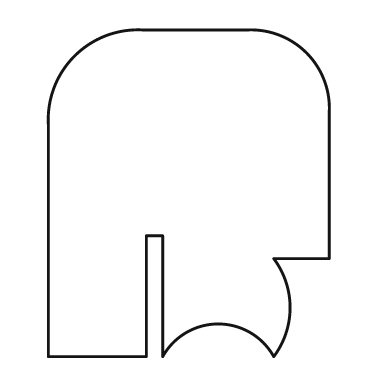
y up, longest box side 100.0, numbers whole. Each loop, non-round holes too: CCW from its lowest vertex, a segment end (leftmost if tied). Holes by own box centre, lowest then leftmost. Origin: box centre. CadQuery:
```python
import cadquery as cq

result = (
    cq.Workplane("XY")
    .moveTo(-43.0, -50.0)
    .lineTo(-13.0, -50.0)
    .lineTo(-13.0, -13.0)
    .lineTo(-8.0, -13.0)
    .lineTo(-8.0, -50.0)
    .threePointArc((9.0, -40.0), (26.0, -50.0))
    .threePointArc((31.0, -35.0), (26.0, -20.0))
    .lineTo(43.0, -20.0)
    .lineTo(43.0, 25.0)
    .threePointArc((36.0, 43.0), (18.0, 50.0))
    .lineTo(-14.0, 50.0)
    .threePointArc((-35.0, 42.0), (-43.0, 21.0))
    .close()
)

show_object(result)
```